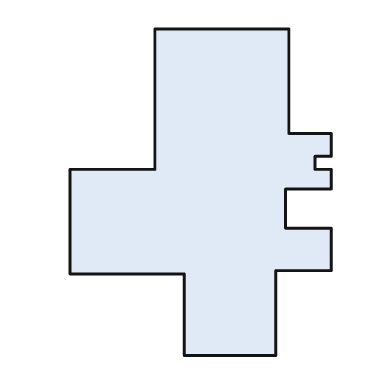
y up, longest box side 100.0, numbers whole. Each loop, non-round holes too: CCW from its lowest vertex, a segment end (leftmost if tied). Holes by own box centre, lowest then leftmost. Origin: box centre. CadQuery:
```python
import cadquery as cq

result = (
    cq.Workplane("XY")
    .moveTo(-5.0, -50.0)
    .lineTo(23.0, -50.0)
    .lineTo(23.0, -24.0)
    .lineTo(40.0, -24.0)
    .lineTo(40.0, -11.0)
    .lineTo(26.0, -11.0)
    .lineTo(26.0, 1.0)
    .lineTo(40.0, 1.0)
    .lineTo(40.0, 7.0)
    .lineTo(35.0, 7.0)
    .lineTo(35.0, 11.0)
    .lineTo(40.0, 11.0)
    .lineTo(40.0, 18.0)
    .lineTo(27.0, 18.0)
    .lineTo(27.0, 50.0)
    .lineTo(-14.0, 50.0)
    .lineTo(-14.0, 7.0)
    .lineTo(-40.0, 7.0)
    .lineTo(-40.0, -25.0)
    .lineTo(-5.0, -25.0)
    .close()
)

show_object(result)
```